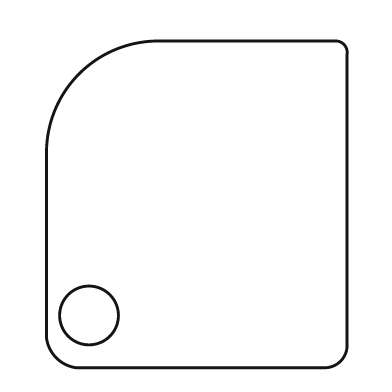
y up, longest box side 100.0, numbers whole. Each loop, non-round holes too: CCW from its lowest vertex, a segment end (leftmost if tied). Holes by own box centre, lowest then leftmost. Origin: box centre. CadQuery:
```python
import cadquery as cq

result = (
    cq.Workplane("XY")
    .moveTo(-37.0, -50.0)
    .lineTo(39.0, -50.0)
    .threePointArc((44.0, -48.0), (46.0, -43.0))
    .lineTo(46.0, 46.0)
    .threePointArc((45.0, 49.0), (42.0, 50.0))
    .lineTo(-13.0, 50.0)
    .threePointArc((-36.0, 40.0), (-46.0, 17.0))
    .lineTo(-46.0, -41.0)
    .threePointArc((-43.0, -47.0), (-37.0, -50.0))
    .close()
    .moveTo(-33.0, -34.0)
    .circle(9.0)
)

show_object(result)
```